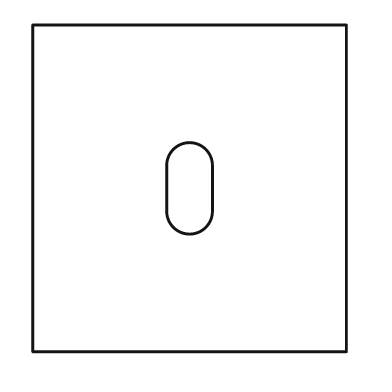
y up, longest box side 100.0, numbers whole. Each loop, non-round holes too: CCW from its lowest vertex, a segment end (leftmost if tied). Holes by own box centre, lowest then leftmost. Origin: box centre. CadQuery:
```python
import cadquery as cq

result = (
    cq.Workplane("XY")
    .moveTo(-48.0, -50.0)
    .lineTo(48.0, -50.0)
    .lineTo(48.0, 50.0)
    .lineTo(-48.0, 50.0)
    .close()
    .moveTo(-7.0, -7.0)
    .threePointArc((0.0, -14.0), (7.0, -7.0))
    .lineTo(7.0, 7.0)
    .threePointArc((0.0, 14.0), (-7.0, 7.0))
    .close()
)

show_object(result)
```